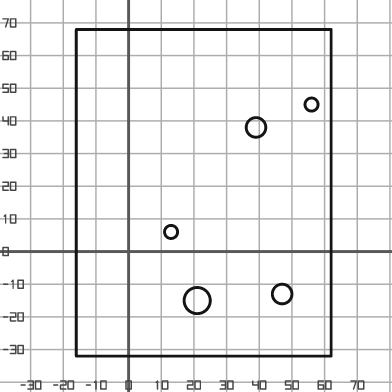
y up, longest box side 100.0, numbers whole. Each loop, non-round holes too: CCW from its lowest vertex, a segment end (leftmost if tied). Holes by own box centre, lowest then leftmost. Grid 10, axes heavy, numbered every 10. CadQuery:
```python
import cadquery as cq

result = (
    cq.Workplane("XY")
    .moveTo(-16.0, -32.0)
    .lineTo(62.0, -32.0)
    .lineTo(62.0, 68.0)
    .lineTo(-16.0, 68.0)
    .close()
    .moveTo(21.0, -15.0)
    .circle(4.0)
    .moveTo(47.0, -13.0)
    .circle(3.0)
    .moveTo(13.0, 6.0)
    .circle(2.0)
    .moveTo(39.0, 38.0)
    .circle(3.0)
    .moveTo(56.0, 45.0)
    .circle(2.0)
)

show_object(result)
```